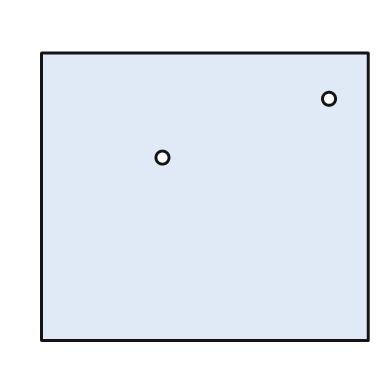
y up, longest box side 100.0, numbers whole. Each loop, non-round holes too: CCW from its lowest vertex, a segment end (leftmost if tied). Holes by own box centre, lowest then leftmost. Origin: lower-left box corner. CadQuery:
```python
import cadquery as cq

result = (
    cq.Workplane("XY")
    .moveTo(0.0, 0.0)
    .lineTo(100.0, 0.0)
    .lineTo(100.0, 88.0)
    .lineTo(0.0, 88.0)
    .close()
    .moveTo(37.0, 56.0)
    .circle(2.0)
    .moveTo(88.0, 74.0)
    .circle(2.0)
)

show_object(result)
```